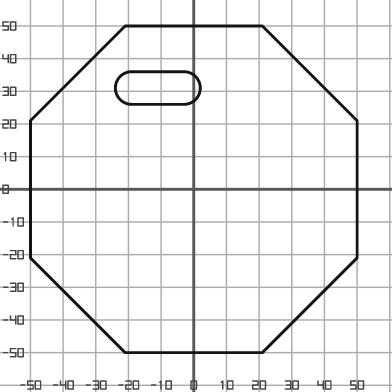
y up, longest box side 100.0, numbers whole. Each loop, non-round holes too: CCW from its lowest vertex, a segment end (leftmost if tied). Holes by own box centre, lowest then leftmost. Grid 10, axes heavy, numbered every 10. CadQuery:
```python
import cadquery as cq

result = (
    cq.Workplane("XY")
    .moveTo(-21.0, -50.0)
    .lineTo(21.0, -50.0)
    .lineTo(50.0, -21.0)
    .lineTo(50.0, 21.0)
    .lineTo(21.0, 50.0)
    .lineTo(-21.0, 50.0)
    .lineTo(-50.0, 21.0)
    .lineTo(-50.0, -21.0)
    .close()
    .moveTo(-19.0, 26.0)
    .lineTo(-3.0, 26.0)
    .threePointArc((2.0, 31.0), (-3.0, 36.0))
    .lineTo(-19.0, 36.0)
    .threePointArc((-24.0, 31.0), (-19.0, 26.0))
    .close()
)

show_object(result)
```